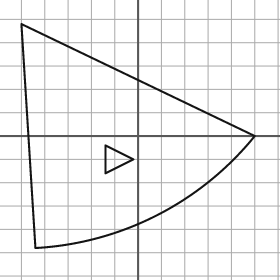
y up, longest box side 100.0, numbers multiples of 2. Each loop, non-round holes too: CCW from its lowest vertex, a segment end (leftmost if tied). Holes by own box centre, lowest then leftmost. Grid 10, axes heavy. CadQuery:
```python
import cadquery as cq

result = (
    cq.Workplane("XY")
    .moveTo(-44.0, -48.0)
    .threePointArc((8.0, -34.0), (50.0, 0.0))
    .lineTo(-50.0, 48.0)
    .close()
    .moveTo(-14.0, -16.0)
    .lineTo(-2.0, -10.0)
    .lineTo(-14.0, -4.0)
    .close()
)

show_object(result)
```